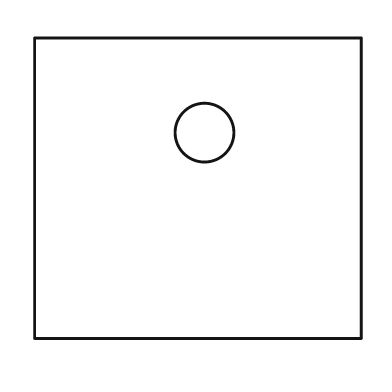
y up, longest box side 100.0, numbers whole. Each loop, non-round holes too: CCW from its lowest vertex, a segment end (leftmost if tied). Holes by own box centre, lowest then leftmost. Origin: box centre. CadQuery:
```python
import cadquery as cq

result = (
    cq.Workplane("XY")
    .moveTo(-50.0, -46.0)
    .lineTo(50.0, -46.0)
    .lineTo(50.0, 46.0)
    .lineTo(-50.0, 46.0)
    .close()
    .moveTo(2.0, 17.0)
    .circle(9.0)
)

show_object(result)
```